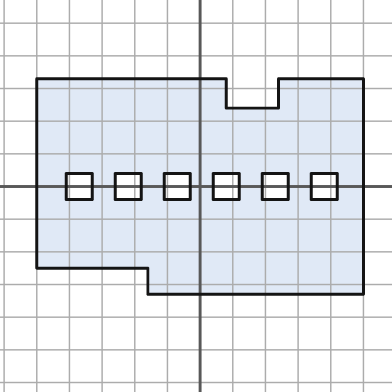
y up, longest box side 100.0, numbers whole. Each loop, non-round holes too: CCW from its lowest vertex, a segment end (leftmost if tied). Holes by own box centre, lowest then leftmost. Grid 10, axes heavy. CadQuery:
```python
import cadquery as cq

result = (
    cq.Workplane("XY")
    .moveTo(-16.0, -33.0)
    .lineTo(50.0, -33.0)
    .lineTo(50.0, 33.0)
    .lineTo(24.0, 33.0)
    .lineTo(24.0, 24.0)
    .lineTo(8.0, 24.0)
    .lineTo(8.0, 33.0)
    .lineTo(-50.0, 33.0)
    .lineTo(-50.0, -25.0)
    .lineTo(-16.0, -25.0)
    .close()
    .moveTo(-41.0, -4.0)
    .lineTo(-33.0, -4.0)
    .lineTo(-33.0, 4.0)
    .lineTo(-41.0, 4.0)
    .close()
    .moveTo(-26.0, -4.0)
    .lineTo(-18.0, -4.0)
    .lineTo(-18.0, 4.0)
    .lineTo(-26.0, 4.0)
    .close()
    .moveTo(-11.0, -4.0)
    .lineTo(-3.0, -4.0)
    .lineTo(-3.0, 4.0)
    .lineTo(-11.0, 4.0)
    .close()
    .moveTo(4.0, -4.0)
    .lineTo(12.0, -4.0)
    .lineTo(12.0, 4.0)
    .lineTo(4.0, 4.0)
    .close()
    .moveTo(19.0, -4.0)
    .lineTo(27.0, -4.0)
    .lineTo(27.0, 4.0)
    .lineTo(19.0, 4.0)
    .close()
    .moveTo(34.0, -4.0)
    .lineTo(42.0, -4.0)
    .lineTo(42.0, 4.0)
    .lineTo(34.0, 4.0)
    .close()
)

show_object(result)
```